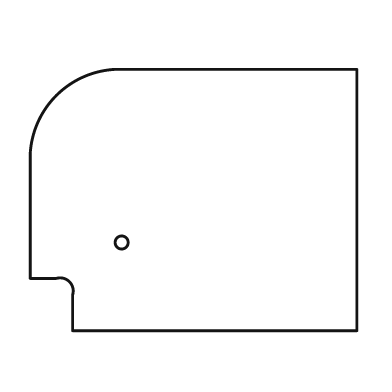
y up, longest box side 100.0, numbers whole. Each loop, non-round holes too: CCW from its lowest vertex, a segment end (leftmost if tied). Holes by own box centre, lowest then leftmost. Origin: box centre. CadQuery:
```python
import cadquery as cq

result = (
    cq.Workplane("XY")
    .moveTo(-37.0, -40.0)
    .lineTo(50.0, -40.0)
    .lineTo(50.0, 40.0)
    .lineTo(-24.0, 40.0)
    .threePointArc((-42.0, 32.0), (-50.0, 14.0))
    .lineTo(-50.0, -24.0)
    .lineTo(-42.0, -24.0)
    .threePointArc((-38.0, -25.0), (-37.0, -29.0))
    .close()
    .moveTo(-22.0, -13.0)
    .circle(2.0)
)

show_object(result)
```